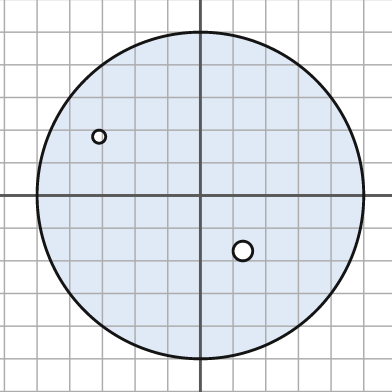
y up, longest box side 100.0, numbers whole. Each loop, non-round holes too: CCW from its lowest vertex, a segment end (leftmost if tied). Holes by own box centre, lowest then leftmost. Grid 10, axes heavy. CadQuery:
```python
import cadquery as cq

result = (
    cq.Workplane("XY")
    .moveTo(0.0, 0.0)
    .circle(50.0)
    .moveTo(13.0, -17.0)
    .circle(3.0)
    .moveTo(-31.0, 18.0)
    .circle(2.0)
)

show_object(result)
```